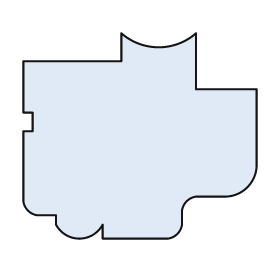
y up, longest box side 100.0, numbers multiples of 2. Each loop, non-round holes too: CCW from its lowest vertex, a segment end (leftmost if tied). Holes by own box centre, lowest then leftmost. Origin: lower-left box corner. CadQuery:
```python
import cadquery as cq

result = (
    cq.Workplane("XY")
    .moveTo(34.0, 0.0)
    .lineTo(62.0, 0.0)
    .threePointArc((66.0, 2.0), (68.0, 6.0))
    .lineTo(68.0, 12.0)
    .threePointArc((70.0, 16.0), (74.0, 18.0))
    .lineTo(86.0, 18.0)
    .threePointArc((96.0, 22.0), (100.0, 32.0))
    .lineTo(100.0, 64.0)
    .lineTo(74.0, 64.0)
    .lineTo(74.0, 88.0)
    .threePointArc((58.0, 82.0), (42.0, 88.0))
    .lineTo(42.0, 76.0)
    .lineTo(0.0, 76.0)
    .lineTo(0.0, 54.0)
    .lineTo(4.0, 54.0)
    .lineTo(4.0, 46.0)
    .lineTo(0.0, 46.0)
    .lineTo(0.0, 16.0)
    .threePointArc((2.0, 12.0), (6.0, 10.0))
    .lineTo(14.0, 10.0)
    .lineTo(14.0, 6.0)
    .threePointArc((24.0, 0.0), (34.0, 6.0))
    .close()
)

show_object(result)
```